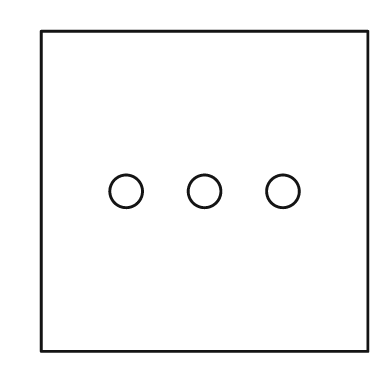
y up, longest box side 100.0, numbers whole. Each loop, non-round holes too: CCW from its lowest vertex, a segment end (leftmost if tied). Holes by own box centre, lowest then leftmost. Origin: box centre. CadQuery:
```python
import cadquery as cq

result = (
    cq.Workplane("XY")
    .moveTo(-50.0, -49.0)
    .lineTo(50.0, -49.0)
    .lineTo(50.0, 49.0)
    .lineTo(-50.0, 49.0)
    .close()
    .moveTo(-24.0, 0.0)
    .circle(5.0)
    .moveTo(0.0, 0.0)
    .circle(5.0)
    .moveTo(24.0, 0.0)
    .circle(5.0)
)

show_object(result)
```